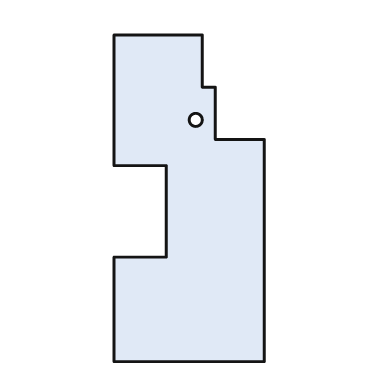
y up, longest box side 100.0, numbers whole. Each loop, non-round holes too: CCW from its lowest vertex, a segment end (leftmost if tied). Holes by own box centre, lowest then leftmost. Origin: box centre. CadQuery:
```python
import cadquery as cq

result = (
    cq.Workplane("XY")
    .moveTo(-23.0, -50.0)
    .lineTo(23.0, -50.0)
    .lineTo(23.0, 18.0)
    .lineTo(8.0, 18.0)
    .lineTo(8.0, 34.0)
    .lineTo(4.0, 34.0)
    .lineTo(4.0, 50.0)
    .lineTo(-23.0, 50.0)
    .lineTo(-23.0, 10.0)
    .lineTo(-7.0, 10.0)
    .lineTo(-7.0, -18.0)
    .lineTo(-23.0, -18.0)
    .close()
    .moveTo(2.0, 24.0)
    .circle(2.0)
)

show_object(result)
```